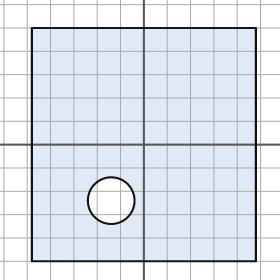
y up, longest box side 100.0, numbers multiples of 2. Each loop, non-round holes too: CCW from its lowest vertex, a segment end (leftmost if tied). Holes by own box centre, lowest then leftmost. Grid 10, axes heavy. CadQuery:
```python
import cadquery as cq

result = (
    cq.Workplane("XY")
    .moveTo(-48.0, -50.0)
    .lineTo(48.0, -50.0)
    .lineTo(48.0, 50.0)
    .lineTo(-48.0, 50.0)
    .close()
    .moveTo(-14.0, -24.0)
    .circle(10.0)
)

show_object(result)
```